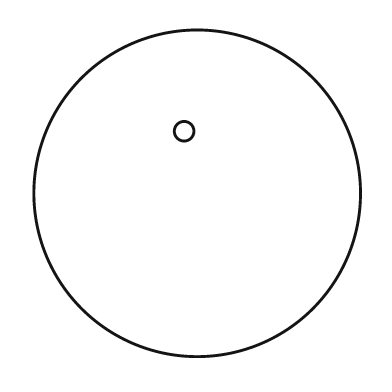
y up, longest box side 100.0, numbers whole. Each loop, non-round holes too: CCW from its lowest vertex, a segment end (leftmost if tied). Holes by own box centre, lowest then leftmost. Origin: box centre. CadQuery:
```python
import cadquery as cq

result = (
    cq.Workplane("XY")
    .moveTo(0.0, 0.0)
    .circle(50.0)
    .moveTo(-4.0, 19.0)
    .circle(3.0)
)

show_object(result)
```